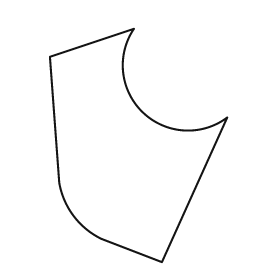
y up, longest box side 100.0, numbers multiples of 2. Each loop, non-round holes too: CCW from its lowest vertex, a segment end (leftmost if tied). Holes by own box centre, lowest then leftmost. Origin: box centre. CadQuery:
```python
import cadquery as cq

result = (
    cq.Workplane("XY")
    .moveTo(10.0, -50.0)
    .lineTo(38.0, 12.0)
    .threePointArc((2.0, 14.0), (-2.0, 50.0))
    .lineTo(-38.0, 38.0)
    .lineTo(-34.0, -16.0)
    .threePointArc((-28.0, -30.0), (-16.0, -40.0))
    .close()
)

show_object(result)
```